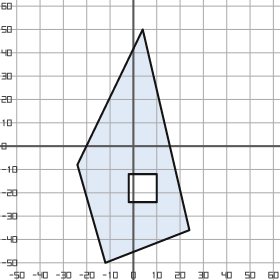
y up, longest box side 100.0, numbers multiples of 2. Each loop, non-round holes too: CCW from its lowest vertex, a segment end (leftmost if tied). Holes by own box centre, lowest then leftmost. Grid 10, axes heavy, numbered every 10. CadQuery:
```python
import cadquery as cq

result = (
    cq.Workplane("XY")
    .moveTo(-12.0, -50.0)
    .lineTo(24.0, -36.0)
    .lineTo(4.0, 50.0)
    .lineTo(-24.0, -8.0)
    .close()
    .moveTo(-2.0, -24.0)
    .lineTo(10.0, -24.0)
    .lineTo(10.0, -12.0)
    .lineTo(-2.0, -12.0)
    .close()
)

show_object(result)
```